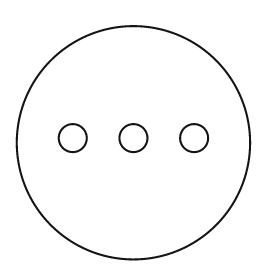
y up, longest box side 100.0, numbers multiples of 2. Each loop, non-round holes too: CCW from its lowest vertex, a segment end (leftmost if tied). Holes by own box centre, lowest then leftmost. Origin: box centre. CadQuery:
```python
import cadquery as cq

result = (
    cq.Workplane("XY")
    .moveTo(0.0, 0.0)
    .circle(50.0)
    .moveTo(-26.0, 2.0)
    .circle(6.0)
    .moveTo(0.0, 2.0)
    .circle(6.0)
    .moveTo(26.0, 2.0)
    .circle(6.0)
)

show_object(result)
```